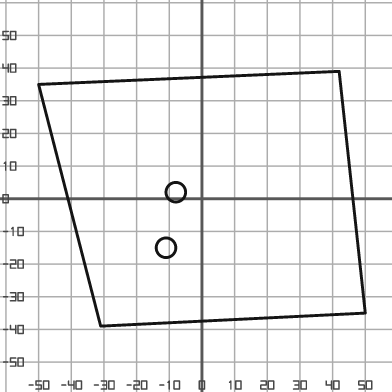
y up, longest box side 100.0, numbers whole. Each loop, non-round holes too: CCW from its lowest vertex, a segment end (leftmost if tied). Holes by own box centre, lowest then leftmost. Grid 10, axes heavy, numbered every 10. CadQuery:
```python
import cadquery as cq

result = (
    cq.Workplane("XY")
    .moveTo(-31.0, -39.0)
    .lineTo(50.0, -35.0)
    .lineTo(42.0, 39.0)
    .lineTo(-50.0, 35.0)
    .close()
    .moveTo(-11.0, -15.0)
    .circle(3.0)
    .moveTo(-8.0, 2.0)
    .circle(3.0)
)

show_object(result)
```